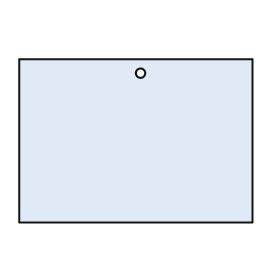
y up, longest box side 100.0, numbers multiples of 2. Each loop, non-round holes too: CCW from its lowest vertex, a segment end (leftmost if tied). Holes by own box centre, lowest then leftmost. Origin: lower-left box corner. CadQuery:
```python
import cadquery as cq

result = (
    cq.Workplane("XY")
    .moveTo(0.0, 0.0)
    .lineTo(100.0, 0.0)
    .lineTo(100.0, 70.0)
    .lineTo(0.0, 70.0)
    .close()
    .moveTo(52.0, 64.0)
    .circle(2.0)
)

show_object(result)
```